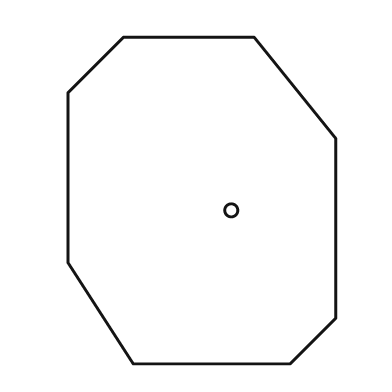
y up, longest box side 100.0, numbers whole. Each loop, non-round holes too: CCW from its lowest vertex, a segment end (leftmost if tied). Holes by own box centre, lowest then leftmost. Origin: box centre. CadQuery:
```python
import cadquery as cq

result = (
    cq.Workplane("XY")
    .moveTo(-21.0, -50.0)
    .lineTo(27.0, -50.0)
    .lineTo(41.0, -36.0)
    .lineTo(41.0, 19.0)
    .lineTo(16.0, 50.0)
    .lineTo(-24.0, 50.0)
    .lineTo(-41.0, 33.0)
    .lineTo(-41.0, -19.0)
    .close()
    .moveTo(9.0, -3.0)
    .circle(2.0)
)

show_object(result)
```